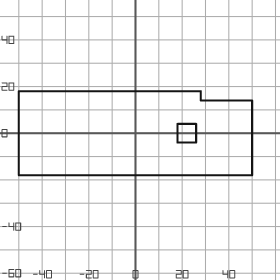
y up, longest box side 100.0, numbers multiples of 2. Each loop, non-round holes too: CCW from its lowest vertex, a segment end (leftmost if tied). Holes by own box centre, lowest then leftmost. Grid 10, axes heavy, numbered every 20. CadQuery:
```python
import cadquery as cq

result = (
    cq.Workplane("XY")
    .moveTo(-50.0, -18.0)
    .lineTo(50.0, -18.0)
    .lineTo(50.0, 14.0)
    .lineTo(28.0, 14.0)
    .lineTo(28.0, 18.0)
    .lineTo(-50.0, 18.0)
    .close()
    .moveTo(18.0, -4.0)
    .lineTo(26.0, -4.0)
    .lineTo(26.0, 4.0)
    .lineTo(18.0, 4.0)
    .close()
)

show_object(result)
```